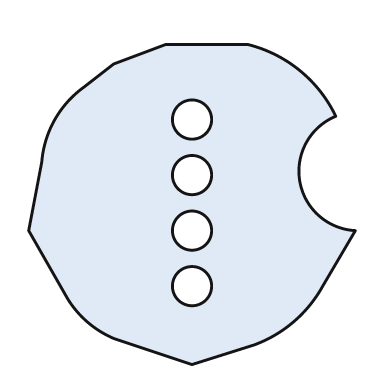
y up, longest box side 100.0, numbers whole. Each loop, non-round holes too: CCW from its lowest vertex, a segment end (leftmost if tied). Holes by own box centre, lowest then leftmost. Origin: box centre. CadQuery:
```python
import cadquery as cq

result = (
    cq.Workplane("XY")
    .moveTo(0.0, -49.0)
    .lineTo(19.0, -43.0)
    .threePointArc((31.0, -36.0), (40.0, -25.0))
    .lineTo(50.0, -8.0)
    .threePointArc((33.0, 7.0), (44.0, 27.0))
    .threePointArc((33.0, 41.0), (17.0, 49.0))
    .lineTo(-8.0, 49.0)
    .lineTo(-24.0, 43.0)
    .lineTo(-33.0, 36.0)
    .threePointArc((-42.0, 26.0), (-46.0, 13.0))
    .lineTo(-50.0, -8.0)
    .lineTo(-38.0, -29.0)
    .threePointArc((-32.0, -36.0), (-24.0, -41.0))
    .close()
    .moveTo(0.0, -25.0)
    .circle(6.0)
    .moveTo(0.0, -8.0)
    .circle(6.0)
    .moveTo(0.0, 9.0)
    .circle(6.0)
    .moveTo(0.0, 26.0)
    .circle(6.0)
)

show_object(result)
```